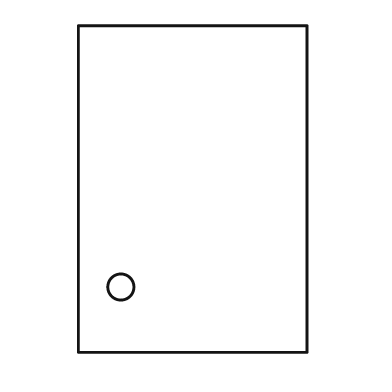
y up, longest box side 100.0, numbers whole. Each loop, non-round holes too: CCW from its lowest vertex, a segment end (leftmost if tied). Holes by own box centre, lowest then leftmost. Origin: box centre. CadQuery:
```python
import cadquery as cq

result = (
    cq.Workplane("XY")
    .moveTo(-35.0, -50.0)
    .lineTo(35.0, -50.0)
    .lineTo(35.0, 50.0)
    .lineTo(-35.0, 50.0)
    .close()
    .moveTo(-22.0, -30.0)
    .circle(4.0)
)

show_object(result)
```